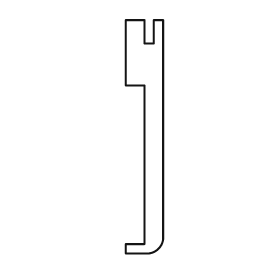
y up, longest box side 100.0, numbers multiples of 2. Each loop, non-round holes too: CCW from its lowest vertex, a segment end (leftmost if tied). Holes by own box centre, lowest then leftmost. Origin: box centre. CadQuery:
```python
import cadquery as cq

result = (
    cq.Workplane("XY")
    .moveTo(-8.0, -50.0)
    .lineTo(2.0, -50.0)
    .threePointArc((6.0, -48.0), (8.0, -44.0))
    .lineTo(8.0, 50.0)
    .lineTo(4.0, 50.0)
    .lineTo(4.0, 40.0)
    .lineTo(0.0, 40.0)
    .lineTo(0.0, 50.0)
    .lineTo(-8.0, 50.0)
    .lineTo(-8.0, 22.0)
    .lineTo(0.0, 22.0)
    .lineTo(0.0, -46.0)
    .lineTo(-8.0, -46.0)
    .close()
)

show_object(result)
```